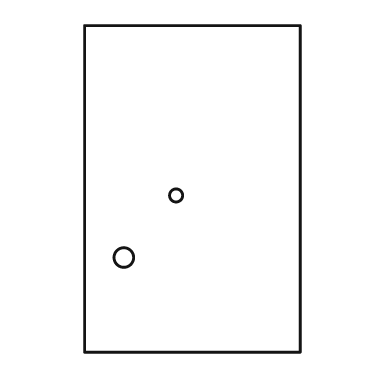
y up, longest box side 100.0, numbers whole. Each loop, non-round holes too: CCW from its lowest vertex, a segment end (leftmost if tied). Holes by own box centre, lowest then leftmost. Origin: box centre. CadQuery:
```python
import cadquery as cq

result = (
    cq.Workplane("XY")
    .moveTo(-33.0, -50.0)
    .lineTo(33.0, -50.0)
    .lineTo(33.0, 50.0)
    .lineTo(-33.0, 50.0)
    .close()
    .moveTo(-21.0, -21.0)
    .circle(3.0)
    .moveTo(-5.0, -2.0)
    .circle(2.0)
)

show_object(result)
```